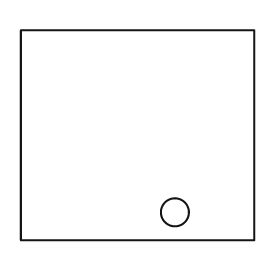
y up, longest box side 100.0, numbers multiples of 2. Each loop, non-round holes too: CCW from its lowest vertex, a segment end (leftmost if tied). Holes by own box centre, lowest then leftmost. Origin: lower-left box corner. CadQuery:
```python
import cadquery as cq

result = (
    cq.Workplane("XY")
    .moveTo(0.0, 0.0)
    .lineTo(100.0, 0.0)
    .lineTo(100.0, 90.0)
    .lineTo(0.0, 90.0)
    .close()
    .moveTo(66.0, 12.0)
    .circle(6.0)
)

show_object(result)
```